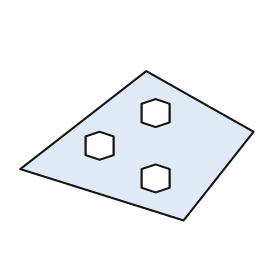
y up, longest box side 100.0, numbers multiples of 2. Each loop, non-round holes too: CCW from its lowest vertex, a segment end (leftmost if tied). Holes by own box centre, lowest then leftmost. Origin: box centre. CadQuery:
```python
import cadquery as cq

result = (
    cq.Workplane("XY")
    .moveTo(20.0, -32.0)
    .lineTo(50.0, 6.0)
    .lineTo(4.0, 32.0)
    .lineTo(-50.0, -10.0)
    .close()
    .moveTo(8.0, -20.0)
    .lineTo(14.0, -18.0)
    .lineTo(14.0, -10.0)
    .lineTo(8.0, -8.0)
    .lineTo(2.0, -10.0)
    .lineTo(2.0, -18.0)
    .close()
    .moveTo(-16.0, -6.0)
    .lineTo(-10.0, -4.0)
    .lineTo(-10.0, 4.0)
    .lineTo(-16.0, 6.0)
    .lineTo(-22.0, 4.0)
    .lineTo(-22.0, -4.0)
    .close()
    .moveTo(8.0, 8.0)
    .lineTo(14.0, 10.0)
    .lineTo(14.0, 18.0)
    .lineTo(8.0, 20.0)
    .lineTo(2.0, 18.0)
    .lineTo(2.0, 10.0)
    .close()
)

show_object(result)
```